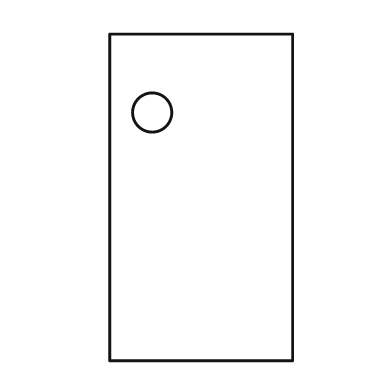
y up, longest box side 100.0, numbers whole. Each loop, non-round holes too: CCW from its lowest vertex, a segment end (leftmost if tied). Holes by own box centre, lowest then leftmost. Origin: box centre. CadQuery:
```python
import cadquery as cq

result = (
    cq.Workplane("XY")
    .moveTo(-28.0, -50.0)
    .lineTo(28.0, -50.0)
    .lineTo(28.0, 50.0)
    .lineTo(-28.0, 50.0)
    .close()
    .moveTo(-15.0, 26.0)
    .circle(6.0)
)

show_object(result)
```